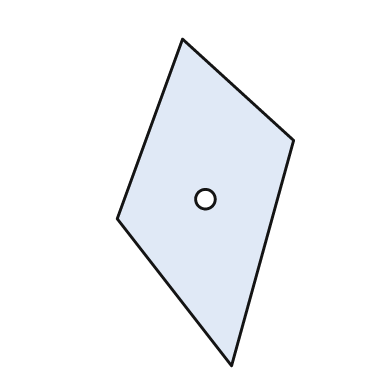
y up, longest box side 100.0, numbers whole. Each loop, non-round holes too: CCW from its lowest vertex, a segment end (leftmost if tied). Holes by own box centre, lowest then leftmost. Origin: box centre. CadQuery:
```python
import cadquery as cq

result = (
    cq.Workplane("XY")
    .moveTo(8.0, -50.0)
    .lineTo(27.0, 19.0)
    .lineTo(-7.0, 50.0)
    .lineTo(-27.0, -5.0)
    .close()
    .moveTo(0.0, 1.0)
    .circle(3.0)
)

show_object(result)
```